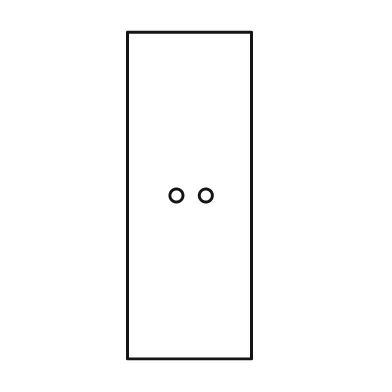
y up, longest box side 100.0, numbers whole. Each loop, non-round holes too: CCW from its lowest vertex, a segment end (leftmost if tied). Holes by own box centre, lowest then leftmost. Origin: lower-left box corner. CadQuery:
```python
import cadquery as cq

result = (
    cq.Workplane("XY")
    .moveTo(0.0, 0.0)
    .lineTo(38.0, 0.0)
    .lineTo(38.0, 100.0)
    .lineTo(0.0, 100.0)
    .close()
    .moveTo(15.0, 50.0)
    .circle(2.0)
    .moveTo(24.0, 50.0)
    .circle(2.0)
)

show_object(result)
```